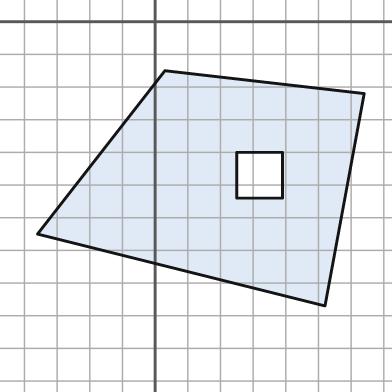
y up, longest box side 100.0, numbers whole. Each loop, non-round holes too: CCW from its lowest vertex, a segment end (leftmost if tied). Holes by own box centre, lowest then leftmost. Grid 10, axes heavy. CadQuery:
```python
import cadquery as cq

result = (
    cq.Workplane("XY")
    .moveTo(52.0, -87.0)
    .lineTo(64.0, -22.0)
    .lineTo(3.0, -15.0)
    .lineTo(-36.0, -65.0)
    .close()
    .moveTo(25.0, -54.0)
    .lineTo(39.0, -54.0)
    .lineTo(39.0, -40.0)
    .lineTo(25.0, -40.0)
    .close()
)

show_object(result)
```